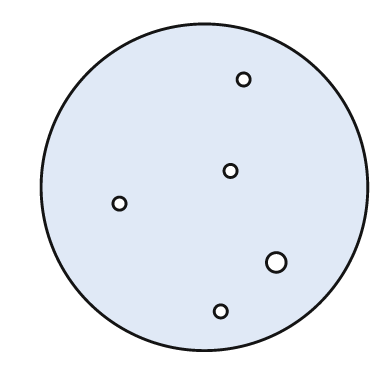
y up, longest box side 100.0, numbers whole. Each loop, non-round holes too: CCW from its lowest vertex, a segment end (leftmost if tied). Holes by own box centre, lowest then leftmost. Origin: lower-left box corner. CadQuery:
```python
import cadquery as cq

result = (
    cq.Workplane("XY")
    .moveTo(50.0, 50.0)
    .circle(50.0)
    .moveTo(55.0, 12.0)
    .circle(2.0)
    .moveTo(72.0, 27.0)
    .circle(3.0)
    .moveTo(24.0, 45.0)
    .circle(2.0)
    .moveTo(58.0, 55.0)
    .circle(2.0)
    .moveTo(62.0, 83.0)
    .circle(2.0)
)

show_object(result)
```